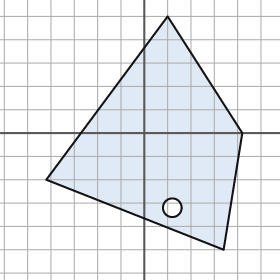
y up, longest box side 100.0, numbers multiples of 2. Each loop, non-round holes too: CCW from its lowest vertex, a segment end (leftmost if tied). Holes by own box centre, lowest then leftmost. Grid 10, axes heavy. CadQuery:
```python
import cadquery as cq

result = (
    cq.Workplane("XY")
    .moveTo(34.0, -50.0)
    .lineTo(42.0, 0.0)
    .lineTo(10.0, 50.0)
    .lineTo(-42.0, -20.0)
    .close()
    .moveTo(12.0, -32.0)
    .circle(4.0)
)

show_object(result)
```